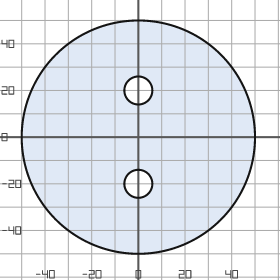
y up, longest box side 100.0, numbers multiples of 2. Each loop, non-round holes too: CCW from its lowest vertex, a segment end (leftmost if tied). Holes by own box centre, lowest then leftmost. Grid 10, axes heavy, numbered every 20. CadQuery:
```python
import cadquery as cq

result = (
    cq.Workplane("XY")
    .moveTo(0.0, 0.0)
    .circle(50.0)
    .moveTo(0.0, -20.0)
    .circle(6.0)
    .moveTo(0.0, 20.0)
    .circle(6.0)
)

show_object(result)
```